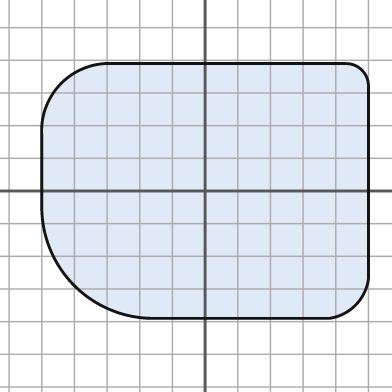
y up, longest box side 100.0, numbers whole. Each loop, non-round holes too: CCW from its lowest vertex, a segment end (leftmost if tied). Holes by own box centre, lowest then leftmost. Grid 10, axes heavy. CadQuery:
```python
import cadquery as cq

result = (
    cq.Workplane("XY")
    .moveTo(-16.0, -39.0)
    .lineTo(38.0, -39.0)
    .threePointArc((46.0, -35.0), (50.0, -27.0))
    .lineTo(50.0, 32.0)
    .threePointArc((48.0, 37.0), (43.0, 39.0))
    .lineTo(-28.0, 39.0)
    .threePointArc((-44.0, 33.0), (-50.0, 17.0))
    .lineTo(-50.0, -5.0)
    .threePointArc((-40.0, -29.0), (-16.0, -39.0))
    .close()
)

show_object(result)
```